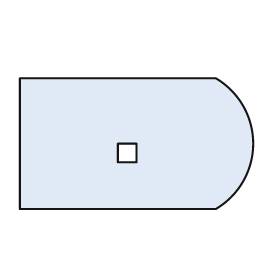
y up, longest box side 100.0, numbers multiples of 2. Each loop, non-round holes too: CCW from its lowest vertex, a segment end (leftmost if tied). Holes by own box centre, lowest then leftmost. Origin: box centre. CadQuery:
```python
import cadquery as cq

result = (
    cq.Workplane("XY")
    .moveTo(-50.0, -28.0)
    .lineTo(34.0, -28.0)
    .threePointArc((50.0, 0.0), (34.0, 28.0))
    .lineTo(-50.0, 28.0)
    .close()
    .moveTo(-8.0, -8.0)
    .lineTo(0.0, -8.0)
    .lineTo(0.0, 0.0)
    .lineTo(-8.0, 0.0)
    .close()
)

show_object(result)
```